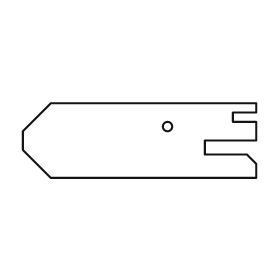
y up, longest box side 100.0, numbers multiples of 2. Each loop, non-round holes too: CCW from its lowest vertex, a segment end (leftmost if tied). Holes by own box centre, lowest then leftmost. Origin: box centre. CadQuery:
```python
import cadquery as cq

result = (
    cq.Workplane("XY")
    .moveTo(-38.0, -16.0)
    .lineTo(50.0, -16.0)
    .lineTo(50.0, -10.0)
    .lineTo(46.0, -6.0)
    .lineTo(28.0, -6.0)
    .lineTo(28.0, 0.0)
    .lineTo(50.0, 0.0)
    .lineTo(50.0, 8.0)
    .lineTo(40.0, 8.0)
    .lineTo(40.0, 12.0)
    .lineTo(50.0, 12.0)
    .lineTo(50.0, 16.0)
    .lineTo(-38.0, 16.0)
    .lineTo(-50.0, 4.0)
    .lineTo(-50.0, -4.0)
    .close()
    .moveTo(12.0, 6.0)
    .circle(2.0)
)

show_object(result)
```